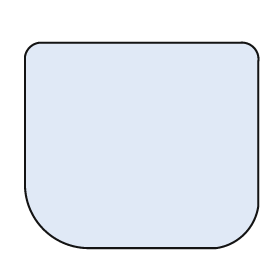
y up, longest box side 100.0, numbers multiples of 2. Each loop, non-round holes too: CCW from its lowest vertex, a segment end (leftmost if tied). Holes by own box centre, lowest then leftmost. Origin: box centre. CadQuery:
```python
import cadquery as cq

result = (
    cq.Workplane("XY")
    .moveTo(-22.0, -44.0)
    .lineTo(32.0, -44.0)
    .threePointArc((44.0, -38.0), (50.0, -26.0))
    .lineTo(50.0, 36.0)
    .threePointArc((48.0, 42.0), (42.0, 44.0))
    .lineTo(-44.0, 44.0)
    .threePointArc((-48.0, 42.0), (-50.0, 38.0))
    .lineTo(-50.0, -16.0)
    .threePointArc((-42.0, -36.0), (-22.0, -44.0))
    .close()
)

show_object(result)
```